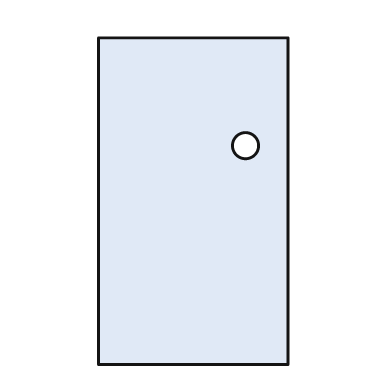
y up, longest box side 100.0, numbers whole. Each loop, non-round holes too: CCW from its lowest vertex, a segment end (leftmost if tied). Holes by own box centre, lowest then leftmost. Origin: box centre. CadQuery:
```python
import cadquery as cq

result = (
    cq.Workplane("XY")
    .moveTo(-29.0, -50.0)
    .lineTo(29.0, -50.0)
    .lineTo(29.0, 50.0)
    .lineTo(-29.0, 50.0)
    .close()
    .moveTo(16.0, 17.0)
    .circle(4.0)
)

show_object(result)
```